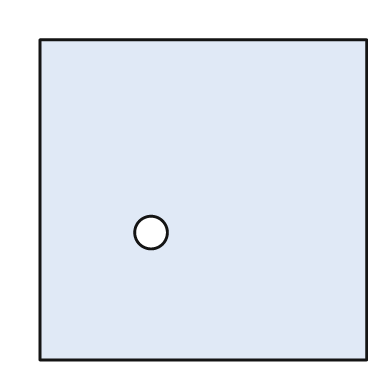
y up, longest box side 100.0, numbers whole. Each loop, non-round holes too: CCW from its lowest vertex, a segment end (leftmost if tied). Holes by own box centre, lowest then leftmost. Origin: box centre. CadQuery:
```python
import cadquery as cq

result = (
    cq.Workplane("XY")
    .moveTo(-50.0, -49.0)
    .lineTo(50.0, -49.0)
    .lineTo(50.0, 49.0)
    .lineTo(-50.0, 49.0)
    .close()
    .moveTo(-16.0, -10.0)
    .circle(5.0)
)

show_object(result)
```